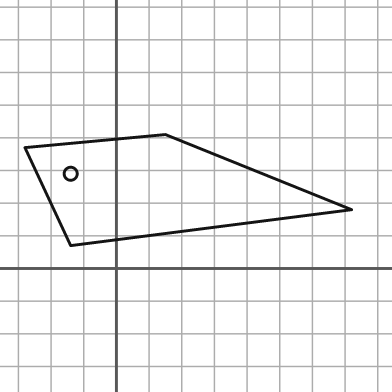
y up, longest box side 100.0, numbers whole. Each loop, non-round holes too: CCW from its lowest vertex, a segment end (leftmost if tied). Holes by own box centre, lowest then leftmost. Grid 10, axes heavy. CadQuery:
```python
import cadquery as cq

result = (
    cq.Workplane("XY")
    .moveTo(-14.0, 7.0)
    .lineTo(72.0, 18.0)
    .lineTo(15.0, 41.0)
    .lineTo(-28.0, 37.0)
    .close()
    .moveTo(-14.0, 29.0)
    .circle(2.0)
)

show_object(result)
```